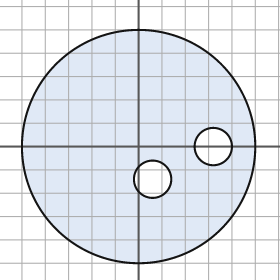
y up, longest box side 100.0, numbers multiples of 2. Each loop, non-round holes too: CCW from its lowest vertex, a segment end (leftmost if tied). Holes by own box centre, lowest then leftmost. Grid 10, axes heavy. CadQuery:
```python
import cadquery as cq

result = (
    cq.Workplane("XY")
    .moveTo(0.0, 0.0)
    .circle(50.0)
    .moveTo(6.0, -14.0)
    .circle(8.0)
    .moveTo(32.0, 0.0)
    .circle(8.0)
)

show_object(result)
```